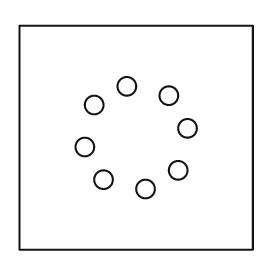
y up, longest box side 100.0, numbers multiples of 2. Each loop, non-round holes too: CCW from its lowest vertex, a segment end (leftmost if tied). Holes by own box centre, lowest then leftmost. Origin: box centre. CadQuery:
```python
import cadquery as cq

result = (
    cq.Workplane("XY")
    .moveTo(-50.0, -48.0)
    .lineTo(50.0, -48.0)
    .lineTo(50.0, 48.0)
    .lineTo(-50.0, 48.0)
    .close()
    .moveTo(4.0, -22.0)
    .circle(4.0)
    .moveTo(-14.0, -18.0)
    .circle(4.0)
    .moveTo(18.0, -14.0)
    .circle(4.0)
    .moveTo(-22.0, -4.0)
    .circle(4.0)
    .moveTo(22.0, 4.0)
    .circle(4.0)
    .moveTo(-18.0, 14.0)
    .circle(4.0)
    .moveTo(14.0, 18.0)
    .circle(4.0)
    .moveTo(-4.0, 22.0)
    .circle(4.0)
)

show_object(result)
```